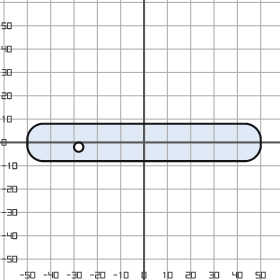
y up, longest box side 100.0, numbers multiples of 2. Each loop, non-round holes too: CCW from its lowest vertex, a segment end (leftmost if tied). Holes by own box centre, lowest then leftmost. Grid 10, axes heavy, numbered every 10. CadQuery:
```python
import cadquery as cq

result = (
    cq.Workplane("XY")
    .moveTo(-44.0, -8.0)
    .lineTo(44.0, -8.0)
    .threePointArc((48.0, -6.0), (50.0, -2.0))
    .lineTo(50.0, 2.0)
    .threePointArc((48.0, 6.0), (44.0, 8.0))
    .lineTo(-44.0, 8.0)
    .threePointArc((-48.0, 6.0), (-50.0, 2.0))
    .lineTo(-50.0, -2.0)
    .threePointArc((-48.0, -6.0), (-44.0, -8.0))
    .close()
    .moveTo(-28.0, -2.0)
    .circle(2.0)
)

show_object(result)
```